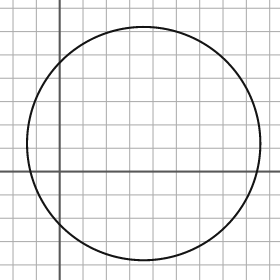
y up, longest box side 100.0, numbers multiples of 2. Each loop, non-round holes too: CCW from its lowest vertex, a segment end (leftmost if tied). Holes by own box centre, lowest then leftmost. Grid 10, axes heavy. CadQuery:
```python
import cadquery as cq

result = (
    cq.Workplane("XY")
    .moveTo(36.0, 12.0)
    .circle(50.0)
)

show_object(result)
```